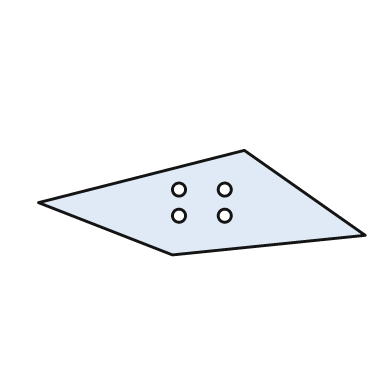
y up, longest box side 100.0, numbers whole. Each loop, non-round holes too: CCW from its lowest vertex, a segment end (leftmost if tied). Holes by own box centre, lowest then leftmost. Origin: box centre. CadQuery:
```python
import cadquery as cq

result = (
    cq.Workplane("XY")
    .moveTo(-9.0, -16.0)
    .lineTo(50.0, -10.0)
    .lineTo(13.0, 16.0)
    .lineTo(-50.0, 0.0)
    .close()
    .moveTo(-7.0, -4.0)
    .circle(2.0)
    .moveTo(7.0, -4.0)
    .circle(2.0)
    .moveTo(-7.0, 4.0)
    .circle(2.0)
    .moveTo(7.0, 4.0)
    .circle(2.0)
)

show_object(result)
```